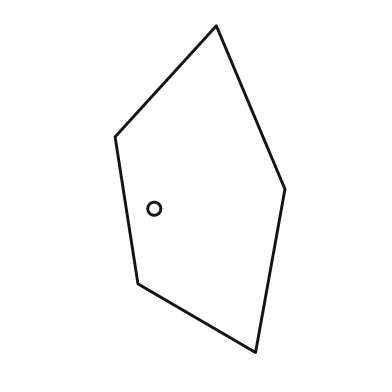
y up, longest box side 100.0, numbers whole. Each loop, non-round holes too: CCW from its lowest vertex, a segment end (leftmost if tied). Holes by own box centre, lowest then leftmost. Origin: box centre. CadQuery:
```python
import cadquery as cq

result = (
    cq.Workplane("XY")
    .moveTo(17.0, -50.0)
    .lineTo(26.0, 0.0)
    .lineTo(5.0, 50.0)
    .lineTo(-26.0, 16.0)
    .lineTo(-19.0, -29.0)
    .close()
    .moveTo(-14.0, -6.0)
    .circle(2.0)
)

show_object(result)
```